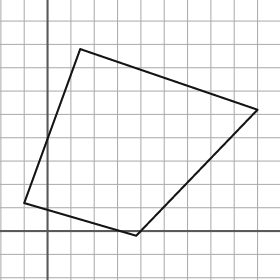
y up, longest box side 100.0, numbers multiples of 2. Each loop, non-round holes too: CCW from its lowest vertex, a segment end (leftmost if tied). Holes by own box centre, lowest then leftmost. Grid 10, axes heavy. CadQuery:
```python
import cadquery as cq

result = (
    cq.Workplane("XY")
    .moveTo(38.0, -2.0)
    .lineTo(90.0, 52.0)
    .lineTo(14.0, 78.0)
    .lineTo(-10.0, 12.0)
    .close()
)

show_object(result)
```